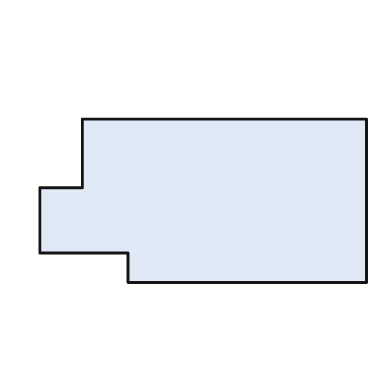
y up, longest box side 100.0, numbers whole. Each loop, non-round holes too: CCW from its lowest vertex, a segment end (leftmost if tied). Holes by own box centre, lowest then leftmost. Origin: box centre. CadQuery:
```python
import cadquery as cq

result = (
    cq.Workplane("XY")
    .moveTo(-23.0, -25.0)
    .lineTo(50.0, -25.0)
    .lineTo(50.0, 25.0)
    .lineTo(-37.0, 25.0)
    .lineTo(-37.0, 4.0)
    .lineTo(-50.0, 4.0)
    .lineTo(-50.0, -16.0)
    .lineTo(-23.0, -16.0)
    .close()
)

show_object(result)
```